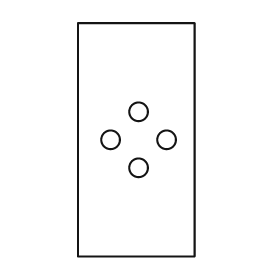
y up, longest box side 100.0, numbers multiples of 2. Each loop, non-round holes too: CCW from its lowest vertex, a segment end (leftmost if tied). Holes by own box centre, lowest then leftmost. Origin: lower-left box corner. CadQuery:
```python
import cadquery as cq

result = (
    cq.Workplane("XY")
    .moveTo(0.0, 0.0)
    .lineTo(50.0, 0.0)
    .lineTo(50.0, 100.0)
    .lineTo(0.0, 100.0)
    .close()
    .moveTo(26.0, 38.0)
    .circle(4.0)
    .moveTo(14.0, 50.0)
    .circle(4.0)
    .moveTo(38.0, 50.0)
    .circle(4.0)
    .moveTo(26.0, 62.0)
    .circle(4.0)
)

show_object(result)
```